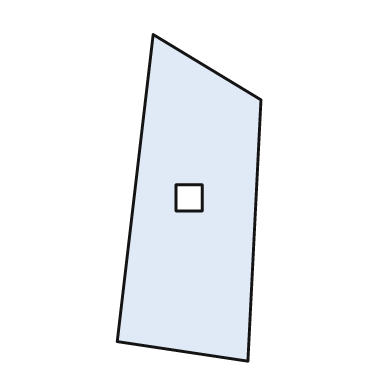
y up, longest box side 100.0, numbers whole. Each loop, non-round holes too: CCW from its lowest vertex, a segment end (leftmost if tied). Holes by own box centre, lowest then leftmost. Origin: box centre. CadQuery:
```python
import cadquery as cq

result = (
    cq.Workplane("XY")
    .moveTo(18.0, -50.0)
    .lineTo(22.0, 30.0)
    .lineTo(-11.0, 50.0)
    .lineTo(-22.0, -44.0)
    .close()
    .moveTo(-4.0, -4.0)
    .lineTo(4.0, -4.0)
    .lineTo(4.0, 4.0)
    .lineTo(-4.0, 4.0)
    .close()
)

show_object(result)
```